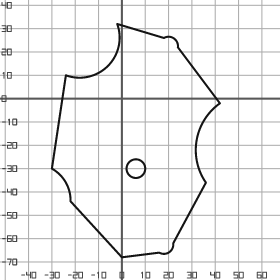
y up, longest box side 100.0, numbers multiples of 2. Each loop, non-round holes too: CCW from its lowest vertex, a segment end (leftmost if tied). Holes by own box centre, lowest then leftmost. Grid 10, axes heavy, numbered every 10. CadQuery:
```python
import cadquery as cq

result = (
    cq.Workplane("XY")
    .moveTo(0.0, -68.0)
    .lineTo(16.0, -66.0)
    .threePointArc((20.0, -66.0), (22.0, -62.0))
    .lineTo(36.0, -36.0)
    .threePointArc((32.0, -18.0), (42.0, -2.0))
    .lineTo(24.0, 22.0)
    .threePointArc((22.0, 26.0), (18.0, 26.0))
    .lineTo(-2.0, 32.0)
    .threePointArc((-6.0, 14.0), (-24.0, 10.0))
    .lineTo(-30.0, -30.0)
    .threePointArc((-24.0, -36.0), (-22.0, -44.0))
    .close()
    .moveTo(6.0, -30.0)
    .circle(4.0)
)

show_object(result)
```